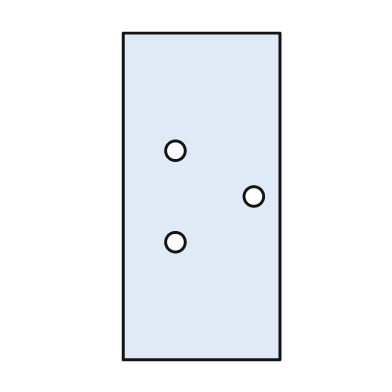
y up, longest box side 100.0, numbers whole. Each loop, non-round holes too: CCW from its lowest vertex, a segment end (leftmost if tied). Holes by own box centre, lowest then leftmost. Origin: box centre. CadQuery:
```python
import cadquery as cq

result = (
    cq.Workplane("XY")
    .moveTo(-24.0, -50.0)
    .lineTo(24.0, -50.0)
    .lineTo(24.0, 50.0)
    .lineTo(-24.0, 50.0)
    .close()
    .moveTo(-8.0, -14.0)
    .circle(3.0)
    .moveTo(16.0, 0.0)
    .circle(3.0)
    .moveTo(-8.0, 14.0)
    .circle(3.0)
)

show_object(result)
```